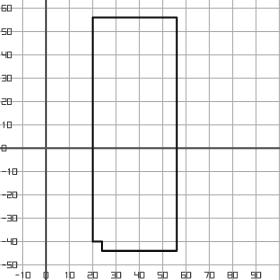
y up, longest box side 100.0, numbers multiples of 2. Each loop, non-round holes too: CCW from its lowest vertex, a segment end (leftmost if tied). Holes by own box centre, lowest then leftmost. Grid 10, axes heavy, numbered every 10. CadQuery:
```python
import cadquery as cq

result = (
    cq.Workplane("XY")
    .moveTo(24.0, -44.0)
    .lineTo(56.0, -44.0)
    .lineTo(56.0, 56.0)
    .lineTo(20.0, 56.0)
    .lineTo(20.0, -40.0)
    .lineTo(24.0, -40.0)
    .close()
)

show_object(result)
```